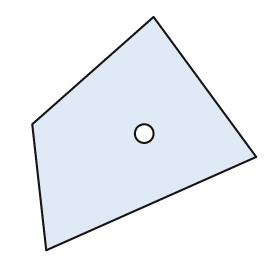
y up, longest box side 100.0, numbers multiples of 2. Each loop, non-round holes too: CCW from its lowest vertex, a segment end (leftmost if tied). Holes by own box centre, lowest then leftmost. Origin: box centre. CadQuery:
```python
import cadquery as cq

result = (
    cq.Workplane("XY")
    .moveTo(-42.0, -50.0)
    .lineTo(48.0, -10.0)
    .lineTo(4.0, 50.0)
    .lineTo(-48.0, 4.0)
    .close()
    .moveTo(0.0, 0.0)
    .circle(4.0)
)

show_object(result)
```